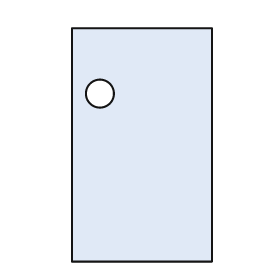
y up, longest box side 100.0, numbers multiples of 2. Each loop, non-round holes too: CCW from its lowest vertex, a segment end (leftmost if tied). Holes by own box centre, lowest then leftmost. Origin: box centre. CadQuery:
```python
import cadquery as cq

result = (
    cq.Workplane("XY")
    .moveTo(-30.0, -50.0)
    .lineTo(30.0, -50.0)
    .lineTo(30.0, 50.0)
    .lineTo(-30.0, 50.0)
    .close()
    .moveTo(-18.0, 22.0)
    .circle(6.0)
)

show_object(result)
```